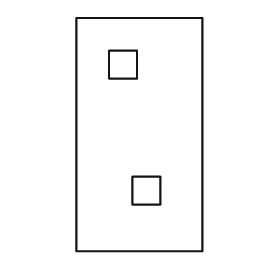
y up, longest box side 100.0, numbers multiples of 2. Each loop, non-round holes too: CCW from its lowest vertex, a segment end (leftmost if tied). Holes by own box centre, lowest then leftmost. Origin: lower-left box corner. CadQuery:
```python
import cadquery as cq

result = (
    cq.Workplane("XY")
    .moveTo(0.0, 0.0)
    .lineTo(54.0, 0.0)
    .lineTo(54.0, 100.0)
    .lineTo(0.0, 100.0)
    .close()
    .moveTo(24.0, 20.0)
    .lineTo(36.0, 20.0)
    .lineTo(36.0, 32.0)
    .lineTo(24.0, 32.0)
    .close()
    .moveTo(14.0, 74.0)
    .lineTo(26.0, 74.0)
    .lineTo(26.0, 86.0)
    .lineTo(14.0, 86.0)
    .close()
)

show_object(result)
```